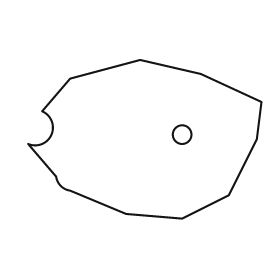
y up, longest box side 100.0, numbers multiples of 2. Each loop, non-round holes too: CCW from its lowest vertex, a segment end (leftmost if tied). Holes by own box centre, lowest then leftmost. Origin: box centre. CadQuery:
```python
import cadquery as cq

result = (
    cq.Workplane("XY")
    .moveTo(16.0, -34.0)
    .lineTo(36.0, -24.0)
    .lineTo(48.0, 0.0)
    .lineTo(50.0, 16.0)
    .lineTo(24.0, 28.0)
    .lineTo(-2.0, 34.0)
    .lineTo(-32.0, 26.0)
    .lineTo(-44.0, 12.0)
    .threePointArc((-40.0, 2.0), (-50.0, -2.0))
    .lineTo(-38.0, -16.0)
    .threePointArc((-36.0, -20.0), (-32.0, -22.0))
    .lineTo(-8.0, -32.0)
    .close()
    .moveTo(16.0, 2.0)
    .circle(4.0)
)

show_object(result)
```